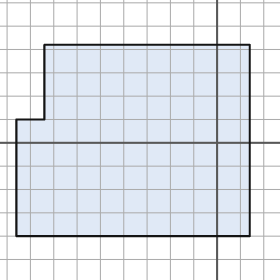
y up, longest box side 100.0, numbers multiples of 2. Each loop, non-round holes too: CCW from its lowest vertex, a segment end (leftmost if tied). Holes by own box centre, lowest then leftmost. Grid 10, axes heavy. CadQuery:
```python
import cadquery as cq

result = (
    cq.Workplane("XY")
    .moveTo(-86.0, -40.0)
    .lineTo(14.0, -40.0)
    .lineTo(14.0, 42.0)
    .lineTo(-74.0, 42.0)
    .lineTo(-74.0, 10.0)
    .lineTo(-86.0, 10.0)
    .close()
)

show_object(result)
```